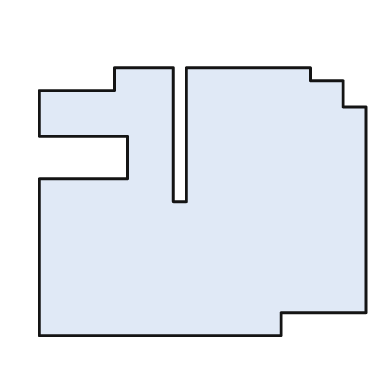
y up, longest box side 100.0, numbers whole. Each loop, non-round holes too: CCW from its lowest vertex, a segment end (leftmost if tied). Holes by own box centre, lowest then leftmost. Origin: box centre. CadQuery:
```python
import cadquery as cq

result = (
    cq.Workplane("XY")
    .moveTo(-50.0, -41.0)
    .lineTo(24.0, -41.0)
    .lineTo(24.0, -34.0)
    .lineTo(50.0, -34.0)
    .lineTo(50.0, 29.0)
    .lineTo(43.0, 29.0)
    .lineTo(43.0, 37.0)
    .lineTo(33.0, 37.0)
    .lineTo(33.0, 41.0)
    .lineTo(-5.0, 41.0)
    .lineTo(-5.0, 0.0)
    .lineTo(-9.0, 0.0)
    .lineTo(-9.0, 41.0)
    .lineTo(-27.0, 41.0)
    .lineTo(-27.0, 34.0)
    .lineTo(-50.0, 34.0)
    .lineTo(-50.0, 20.0)
    .lineTo(-23.0, 20.0)
    .lineTo(-23.0, 7.0)
    .lineTo(-50.0, 7.0)
    .close()
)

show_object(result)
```